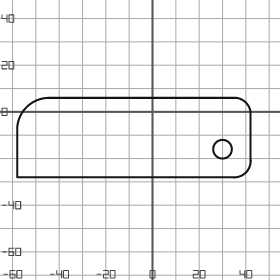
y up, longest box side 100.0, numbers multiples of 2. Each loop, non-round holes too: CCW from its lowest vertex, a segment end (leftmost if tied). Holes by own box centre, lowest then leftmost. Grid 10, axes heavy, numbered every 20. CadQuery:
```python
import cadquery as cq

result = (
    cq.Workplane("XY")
    .moveTo(-58.0, -28.0)
    .lineTo(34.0, -28.0)
    .threePointArc((40.0, -26.0), (42.0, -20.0))
    .lineTo(42.0, 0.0)
    .threePointArc((40.0, 4.0), (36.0, 6.0))
    .lineTo(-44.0, 6.0)
    .threePointArc((-54.0, 2.0), (-58.0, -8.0))
    .close()
    .moveTo(30.0, -16.0)
    .circle(4.0)
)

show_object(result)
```